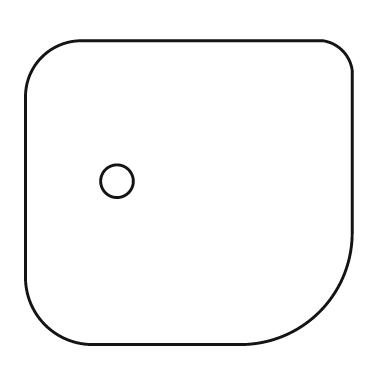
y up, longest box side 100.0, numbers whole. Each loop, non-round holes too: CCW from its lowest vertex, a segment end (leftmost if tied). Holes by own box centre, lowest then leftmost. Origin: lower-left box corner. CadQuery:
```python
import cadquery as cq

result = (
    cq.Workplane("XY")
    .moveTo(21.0, 0.0)
    .lineTo(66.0, 0.0)
    .threePointArc((90.0, 10.0), (100.0, 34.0))
    .lineTo(100.0, 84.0)
    .threePointArc((97.0, 90.0), (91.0, 93.0))
    .lineTo(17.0, 93.0)
    .threePointArc((5.0, 88.0), (0.0, 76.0))
    .lineTo(0.0, 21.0)
    .threePointArc((6.0, 6.0), (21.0, 0.0))
    .close()
    .moveTo(28.0, 50.0)
    .circle(5.0)
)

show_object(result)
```